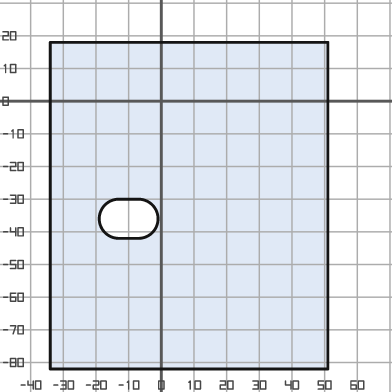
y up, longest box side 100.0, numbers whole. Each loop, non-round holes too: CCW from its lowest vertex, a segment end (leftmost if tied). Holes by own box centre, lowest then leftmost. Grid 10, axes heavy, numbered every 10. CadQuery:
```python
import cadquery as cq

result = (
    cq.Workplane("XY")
    .moveTo(-34.0, -82.0)
    .lineTo(51.0, -82.0)
    .lineTo(51.0, 18.0)
    .lineTo(-34.0, 18.0)
    .close()
    .moveTo(-13.0, -42.0)
    .lineTo(-7.0, -42.0)
    .threePointArc((-1.0, -36.0), (-7.0, -30.0))
    .lineTo(-13.0, -30.0)
    .threePointArc((-19.0, -36.0), (-13.0, -42.0))
    .close()
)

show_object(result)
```